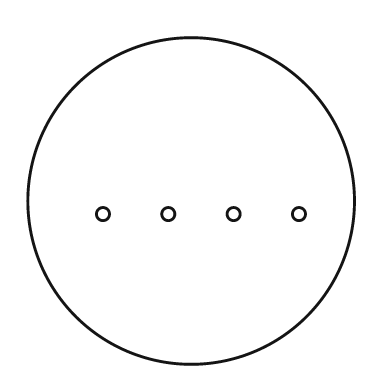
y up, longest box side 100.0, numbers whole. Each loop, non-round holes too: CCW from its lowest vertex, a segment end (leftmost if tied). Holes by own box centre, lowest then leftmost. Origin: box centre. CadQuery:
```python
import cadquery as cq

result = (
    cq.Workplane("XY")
    .moveTo(0.0, 0.0)
    .circle(50.0)
    .moveTo(-27.0, -4.0)
    .circle(2.0)
    .moveTo(-7.0, -4.0)
    .circle(2.0)
    .moveTo(13.0, -4.0)
    .circle(2.0)
    .moveTo(33.0, -4.0)
    .circle(2.0)
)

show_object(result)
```